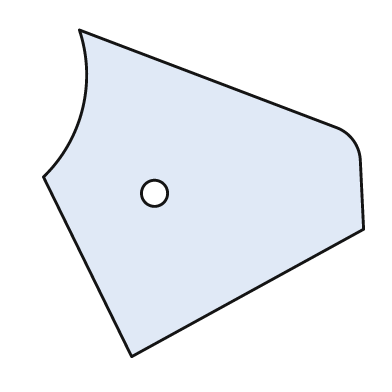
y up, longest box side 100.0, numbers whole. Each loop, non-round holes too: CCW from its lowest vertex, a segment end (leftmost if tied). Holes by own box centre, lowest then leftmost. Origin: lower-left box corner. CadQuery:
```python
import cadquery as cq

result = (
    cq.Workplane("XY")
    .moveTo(27.0, 0.0)
    .lineTo(98.0, 39.0)
    .lineTo(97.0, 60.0)
    .threePointArc((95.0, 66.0), (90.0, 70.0))
    .lineTo(11.0, 100.0)
    .threePointArc((12.0, 76.0), (0.0, 55.0))
    .close()
    .moveTo(34.0, 50.0)
    .circle(4.0)
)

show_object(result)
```